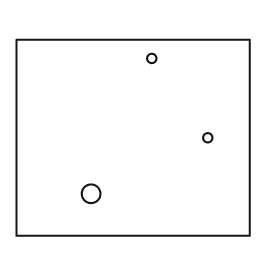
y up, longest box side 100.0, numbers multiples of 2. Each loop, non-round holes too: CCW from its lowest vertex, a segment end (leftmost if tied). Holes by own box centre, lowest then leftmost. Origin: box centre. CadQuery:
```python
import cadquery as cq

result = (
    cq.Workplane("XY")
    .moveTo(-50.0, -42.0)
    .lineTo(50.0, -42.0)
    .lineTo(50.0, 42.0)
    .lineTo(-50.0, 42.0)
    .close()
    .moveTo(-18.0, -24.0)
    .circle(4.0)
    .moveTo(32.0, 0.0)
    .circle(2.0)
    .moveTo(8.0, 34.0)
    .circle(2.0)
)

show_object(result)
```